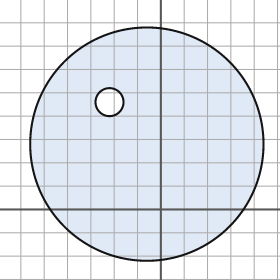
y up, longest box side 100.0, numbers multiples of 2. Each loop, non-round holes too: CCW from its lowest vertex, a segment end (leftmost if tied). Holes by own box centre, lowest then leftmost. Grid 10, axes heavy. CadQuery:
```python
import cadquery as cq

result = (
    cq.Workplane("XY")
    .moveTo(-6.0, 28.0)
    .circle(50.0)
    .moveTo(-22.0, 46.0)
    .circle(6.0)
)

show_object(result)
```